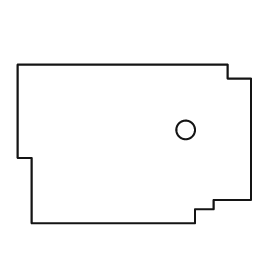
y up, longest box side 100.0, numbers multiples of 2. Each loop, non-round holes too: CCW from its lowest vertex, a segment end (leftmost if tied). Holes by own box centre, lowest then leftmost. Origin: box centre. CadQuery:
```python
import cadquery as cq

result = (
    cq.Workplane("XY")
    .moveTo(-44.0, -34.0)
    .lineTo(26.0, -34.0)
    .lineTo(26.0, -28.0)
    .lineTo(34.0, -28.0)
    .lineTo(34.0, -24.0)
    .lineTo(50.0, -24.0)
    .lineTo(50.0, 28.0)
    .lineTo(40.0, 28.0)
    .lineTo(40.0, 34.0)
    .lineTo(-50.0, 34.0)
    .lineTo(-50.0, -6.0)
    .lineTo(-44.0, -6.0)
    .close()
    .moveTo(22.0, 6.0)
    .circle(4.0)
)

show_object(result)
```